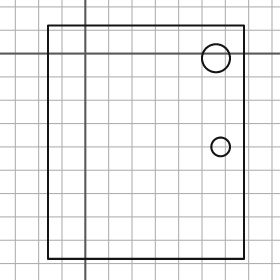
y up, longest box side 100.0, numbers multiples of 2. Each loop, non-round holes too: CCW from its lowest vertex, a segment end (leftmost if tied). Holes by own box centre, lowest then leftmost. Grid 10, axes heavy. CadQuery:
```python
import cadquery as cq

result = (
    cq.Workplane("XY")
    .moveTo(-16.0, -88.0)
    .lineTo(68.0, -88.0)
    .lineTo(68.0, 12.0)
    .lineTo(-16.0, 12.0)
    .close()
    .moveTo(58.0, -40.0)
    .circle(4.0)
    .moveTo(56.0, -2.0)
    .circle(6.0)
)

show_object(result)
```